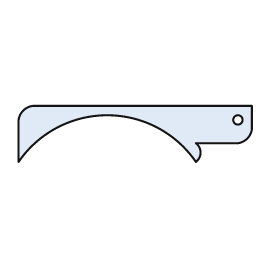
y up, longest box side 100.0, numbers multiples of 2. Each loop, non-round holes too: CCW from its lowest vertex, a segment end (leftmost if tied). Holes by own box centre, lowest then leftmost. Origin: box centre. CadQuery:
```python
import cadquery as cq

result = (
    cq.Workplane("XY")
    .moveTo(-50.0, -12.0)
    .threePointArc((-12.0, 8.0), (26.0, -12.0))
    .threePointArc((28.0, -8.0), (26.0, -4.0))
    .lineTo(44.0, -4.0)
    .threePointArc((48.0, -2.0), (50.0, 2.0))
    .lineTo(50.0, 12.0)
    .lineTo(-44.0, 12.0)
    .threePointArc((-48.0, 10.0), (-50.0, 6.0))
    .close()
    .moveTo(44.0, 6.0)
    .circle(2.0)
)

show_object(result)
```